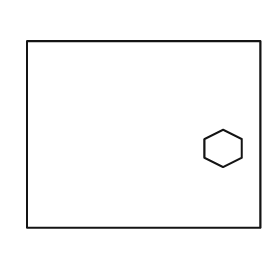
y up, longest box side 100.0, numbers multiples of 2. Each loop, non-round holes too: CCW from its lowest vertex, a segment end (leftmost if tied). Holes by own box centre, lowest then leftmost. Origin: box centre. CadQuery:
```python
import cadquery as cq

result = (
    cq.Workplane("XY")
    .moveTo(-50.0, -40.0)
    .lineTo(50.0, -40.0)
    .lineTo(50.0, 40.0)
    .lineTo(-50.0, 40.0)
    .close()
    .moveTo(34.0, -14.0)
    .lineTo(42.0, -10.0)
    .lineTo(42.0, -2.0)
    .lineTo(34.0, 2.0)
    .lineTo(26.0, -2.0)
    .lineTo(26.0, -10.0)
    .close()
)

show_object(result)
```